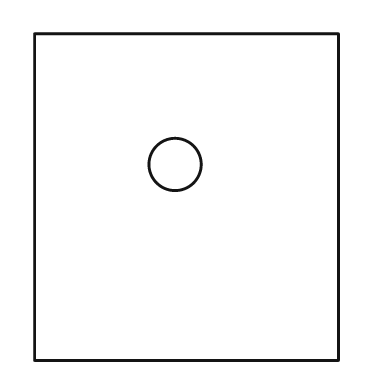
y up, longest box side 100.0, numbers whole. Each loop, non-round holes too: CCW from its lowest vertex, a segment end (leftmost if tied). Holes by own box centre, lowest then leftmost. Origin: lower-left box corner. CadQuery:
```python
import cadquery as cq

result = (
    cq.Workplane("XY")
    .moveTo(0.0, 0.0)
    .lineTo(93.0, 0.0)
    .lineTo(93.0, 100.0)
    .lineTo(0.0, 100.0)
    .close()
    .moveTo(43.0, 60.0)
    .circle(8.0)
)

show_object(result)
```